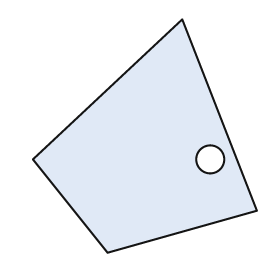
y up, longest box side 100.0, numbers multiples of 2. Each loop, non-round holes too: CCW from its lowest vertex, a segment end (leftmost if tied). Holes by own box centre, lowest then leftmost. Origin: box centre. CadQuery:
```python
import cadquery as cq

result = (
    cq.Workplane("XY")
    .moveTo(-16.0, -50.0)
    .lineTo(48.0, -32.0)
    .lineTo(16.0, 50.0)
    .lineTo(-48.0, -10.0)
    .close()
    .moveTo(28.0, -10.0)
    .circle(6.0)
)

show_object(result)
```